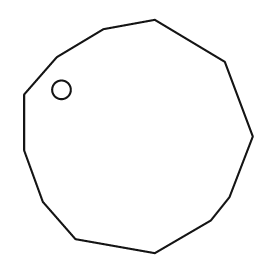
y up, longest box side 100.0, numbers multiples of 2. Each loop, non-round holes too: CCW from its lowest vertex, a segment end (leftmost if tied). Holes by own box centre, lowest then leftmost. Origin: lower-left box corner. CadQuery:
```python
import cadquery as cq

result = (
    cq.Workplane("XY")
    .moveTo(56.0, 0.0)
    .lineTo(80.0, 14.0)
    .lineTo(88.0, 24.0)
    .lineTo(98.0, 50.0)
    .lineTo(86.0, 82.0)
    .lineTo(56.0, 100.0)
    .lineTo(34.0, 96.0)
    .lineTo(14.0, 84.0)
    .lineTo(0.0, 68.0)
    .lineTo(0.0, 44.0)
    .lineTo(8.0, 22.0)
    .lineTo(22.0, 6.0)
    .close()
    .moveTo(16.0, 70.0)
    .circle(4.0)
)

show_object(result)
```